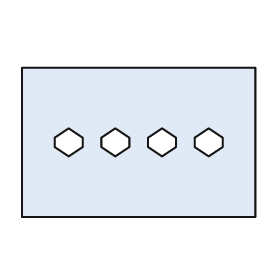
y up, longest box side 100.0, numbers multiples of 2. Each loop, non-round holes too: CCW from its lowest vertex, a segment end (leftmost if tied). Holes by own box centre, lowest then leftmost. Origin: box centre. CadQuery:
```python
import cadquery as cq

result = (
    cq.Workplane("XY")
    .moveTo(-50.0, -32.0)
    .lineTo(50.0, -32.0)
    .lineTo(50.0, 32.0)
    .lineTo(-50.0, 32.0)
    .close()
    .moveTo(-30.0, -6.0)
    .lineTo(-24.0, -2.0)
    .lineTo(-24.0, 2.0)
    .lineTo(-30.0, 6.0)
    .lineTo(-36.0, 2.0)
    .lineTo(-36.0, -2.0)
    .close()
    .moveTo(-10.0, -6.0)
    .lineTo(-4.0, -2.0)
    .lineTo(-4.0, 2.0)
    .lineTo(-10.0, 6.0)
    .lineTo(-16.0, 2.0)
    .lineTo(-16.0, -2.0)
    .close()
    .moveTo(10.0, -6.0)
    .lineTo(16.0, -2.0)
    .lineTo(16.0, 2.0)
    .lineTo(10.0, 6.0)
    .lineTo(4.0, 2.0)
    .lineTo(4.0, -2.0)
    .close()
    .moveTo(30.0, -6.0)
    .lineTo(36.0, -2.0)
    .lineTo(36.0, 2.0)
    .lineTo(30.0, 6.0)
    .lineTo(24.0, 2.0)
    .lineTo(24.0, -2.0)
    .close()
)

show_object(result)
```